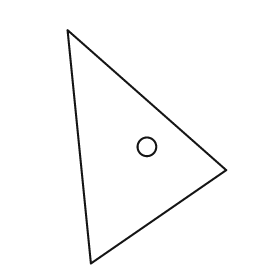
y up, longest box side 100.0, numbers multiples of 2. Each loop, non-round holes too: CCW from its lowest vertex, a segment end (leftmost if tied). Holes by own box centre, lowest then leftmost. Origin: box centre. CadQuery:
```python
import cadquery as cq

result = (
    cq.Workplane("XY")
    .moveTo(-24.0, -50.0)
    .lineTo(34.0, -10.0)
    .lineTo(-34.0, 50.0)
    .close()
    .moveTo(0.0, 0.0)
    .circle(4.0)
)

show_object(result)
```